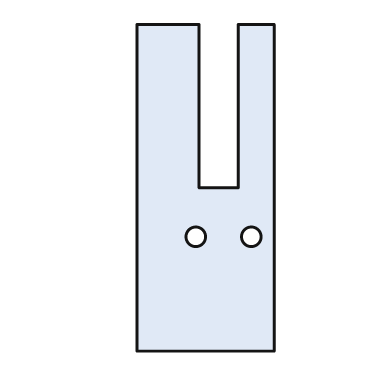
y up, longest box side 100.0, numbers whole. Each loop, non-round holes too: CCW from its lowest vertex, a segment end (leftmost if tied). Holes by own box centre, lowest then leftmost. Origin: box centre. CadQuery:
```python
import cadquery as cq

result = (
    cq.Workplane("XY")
    .moveTo(-21.0, -50.0)
    .lineTo(21.0, -50.0)
    .lineTo(21.0, 50.0)
    .lineTo(10.0, 50.0)
    .lineTo(10.0, 0.0)
    .lineTo(-2.0, 0.0)
    .lineTo(-2.0, 50.0)
    .lineTo(-21.0, 50.0)
    .close()
    .moveTo(-3.0, -15.0)
    .circle(3.0)
    .moveTo(14.0, -15.0)
    .circle(3.0)
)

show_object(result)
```